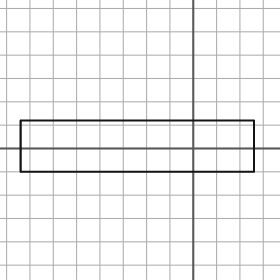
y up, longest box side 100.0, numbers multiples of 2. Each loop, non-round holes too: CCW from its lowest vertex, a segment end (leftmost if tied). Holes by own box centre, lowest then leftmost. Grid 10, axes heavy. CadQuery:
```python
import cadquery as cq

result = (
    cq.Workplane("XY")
    .moveTo(-74.0, -10.0)
    .lineTo(26.0, -10.0)
    .lineTo(26.0, 12.0)
    .lineTo(-74.0, 12.0)
    .close()
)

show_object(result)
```